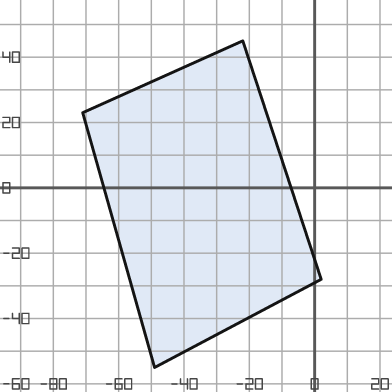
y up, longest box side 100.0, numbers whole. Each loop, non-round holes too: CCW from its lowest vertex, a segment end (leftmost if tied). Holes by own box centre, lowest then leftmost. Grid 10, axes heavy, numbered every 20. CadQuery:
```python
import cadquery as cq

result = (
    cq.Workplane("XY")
    .moveTo(-49.0, -55.0)
    .lineTo(2.0, -28.0)
    .lineTo(-22.0, 45.0)
    .lineTo(-71.0, 23.0)
    .close()
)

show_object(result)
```